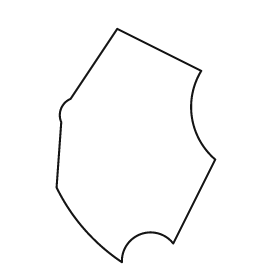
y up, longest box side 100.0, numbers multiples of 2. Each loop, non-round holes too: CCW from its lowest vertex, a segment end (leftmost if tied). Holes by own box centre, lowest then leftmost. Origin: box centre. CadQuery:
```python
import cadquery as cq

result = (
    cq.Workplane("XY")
    .moveTo(-6.0, -50.0)
    .threePointArc((2.0, -38.0), (16.0, -42.0))
    .lineTo(34.0, -6.0)
    .threePointArc((24.0, 12.0), (28.0, 32.0))
    .lineTo(-8.0, 50.0)
    .lineTo(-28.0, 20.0)
    .threePointArc((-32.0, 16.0), (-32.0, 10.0))
    .lineTo(-34.0, -18.0)
    .threePointArc((-22.0, -36.0), (-6.0, -50.0))
    .close()
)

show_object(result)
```